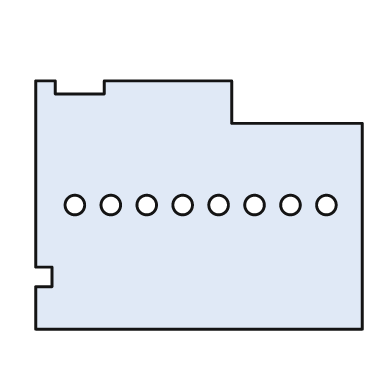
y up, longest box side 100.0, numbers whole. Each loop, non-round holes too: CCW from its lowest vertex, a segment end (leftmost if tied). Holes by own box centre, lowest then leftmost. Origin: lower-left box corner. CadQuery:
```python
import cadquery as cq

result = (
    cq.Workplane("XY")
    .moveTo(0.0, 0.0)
    .lineTo(100.0, 0.0)
    .lineTo(100.0, 63.0)
    .lineTo(60.0, 63.0)
    .lineTo(60.0, 76.0)
    .lineTo(21.0, 76.0)
    .lineTo(21.0, 72.0)
    .lineTo(6.0, 72.0)
    .lineTo(6.0, 76.0)
    .lineTo(0.0, 76.0)
    .lineTo(0.0, 19.0)
    .lineTo(5.0, 19.0)
    .lineTo(5.0, 13.0)
    .lineTo(0.0, 13.0)
    .close()
    .moveTo(12.0, 38.0)
    .circle(3.0)
    .moveTo(23.0, 38.0)
    .circle(3.0)
    .moveTo(34.0, 38.0)
    .circle(3.0)
    .moveTo(45.0, 38.0)
    .circle(3.0)
    .moveTo(56.0, 38.0)
    .circle(3.0)
    .moveTo(67.0, 38.0)
    .circle(3.0)
    .moveTo(78.0, 38.0)
    .circle(3.0)
    .moveTo(89.0, 38.0)
    .circle(3.0)
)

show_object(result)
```